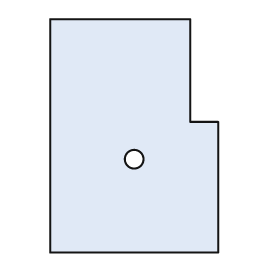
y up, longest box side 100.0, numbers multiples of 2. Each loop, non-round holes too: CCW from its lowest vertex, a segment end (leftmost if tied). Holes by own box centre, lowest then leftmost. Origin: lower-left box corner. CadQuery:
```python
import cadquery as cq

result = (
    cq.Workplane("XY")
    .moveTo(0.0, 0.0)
    .lineTo(72.0, 0.0)
    .lineTo(72.0, 56.0)
    .lineTo(60.0, 56.0)
    .lineTo(60.0, 100.0)
    .lineTo(0.0, 100.0)
    .close()
    .moveTo(36.0, 40.0)
    .circle(4.0)
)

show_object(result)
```